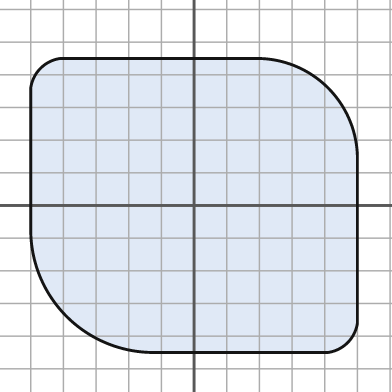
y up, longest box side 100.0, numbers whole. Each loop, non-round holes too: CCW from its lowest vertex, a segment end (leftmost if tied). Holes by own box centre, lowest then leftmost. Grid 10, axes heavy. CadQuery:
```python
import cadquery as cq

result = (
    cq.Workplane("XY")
    .moveTo(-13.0, -45.0)
    .lineTo(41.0, -45.0)
    .threePointArc((47.0, -42.0), (50.0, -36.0))
    .lineTo(50.0, 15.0)
    .threePointArc((41.0, 36.0), (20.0, 45.0))
    .lineTo(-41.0, 45.0)
    .threePointArc((-47.0, 42.0), (-50.0, 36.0))
    .lineTo(-50.0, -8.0)
    .threePointArc((-39.0, -34.0), (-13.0, -45.0))
    .close()
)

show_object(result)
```